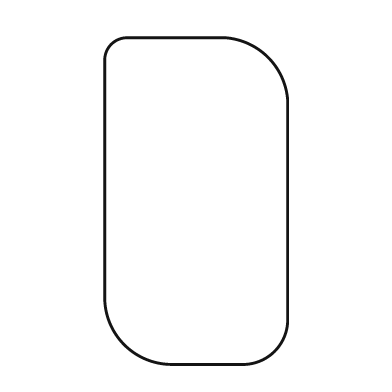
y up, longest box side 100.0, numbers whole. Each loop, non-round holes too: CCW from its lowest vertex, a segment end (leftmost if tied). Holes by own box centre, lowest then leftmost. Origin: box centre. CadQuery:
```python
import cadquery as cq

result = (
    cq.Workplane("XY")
    .moveTo(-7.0, -50.0)
    .lineTo(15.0, -50.0)
    .threePointArc((24.0, -46.0), (28.0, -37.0))
    .lineTo(28.0, 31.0)
    .threePointArc((22.0, 44.0), (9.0, 50.0))
    .lineTo(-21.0, 50.0)
    .threePointArc((-26.0, 48.0), (-28.0, 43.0))
    .lineTo(-28.0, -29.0)
    .threePointArc((-22.0, -44.0), (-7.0, -50.0))
    .close()
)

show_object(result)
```